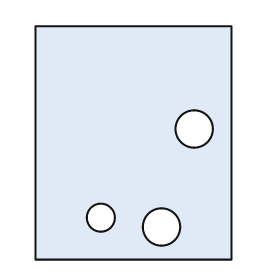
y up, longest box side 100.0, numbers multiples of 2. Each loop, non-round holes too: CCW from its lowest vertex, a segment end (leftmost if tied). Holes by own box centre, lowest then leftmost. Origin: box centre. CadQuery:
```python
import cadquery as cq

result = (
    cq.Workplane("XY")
    .moveTo(-42.0, -50.0)
    .lineTo(42.0, -50.0)
    .lineTo(42.0, 50.0)
    .lineTo(-42.0, 50.0)
    .close()
    .moveTo(12.0, -36.0)
    .circle(8.0)
    .moveTo(-14.0, -32.0)
    .circle(6.0)
    .moveTo(26.0, 6.0)
    .circle(8.0)
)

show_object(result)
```